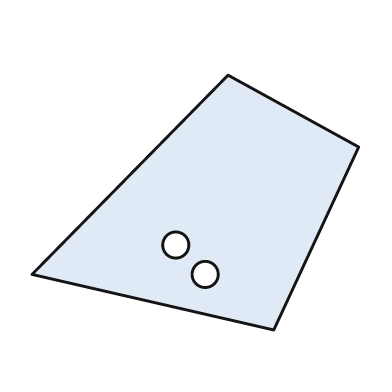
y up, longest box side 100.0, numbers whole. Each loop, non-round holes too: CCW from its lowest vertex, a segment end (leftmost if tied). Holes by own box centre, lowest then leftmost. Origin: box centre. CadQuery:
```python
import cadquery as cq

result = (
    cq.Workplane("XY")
    .moveTo(24.0, -39.0)
    .lineTo(50.0, 17.0)
    .lineTo(10.0, 39.0)
    .lineTo(-50.0, -22.0)
    .close()
    .moveTo(3.0, -22.0)
    .circle(4.0)
    .moveTo(-6.0, -13.0)
    .circle(4.0)
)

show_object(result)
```